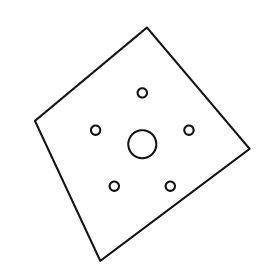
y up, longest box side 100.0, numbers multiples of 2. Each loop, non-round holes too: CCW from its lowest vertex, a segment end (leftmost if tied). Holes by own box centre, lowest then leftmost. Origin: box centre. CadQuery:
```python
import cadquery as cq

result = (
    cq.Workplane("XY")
    .moveTo(-18.0, -50.0)
    .lineTo(46.0, -2.0)
    .lineTo(2.0, 50.0)
    .lineTo(-46.0, 10.0)
    .close()
    .moveTo(-12.0, -18.0)
    .circle(2.0)
    .moveTo(12.0, -18.0)
    .circle(2.0)
    .moveTo(0.0, 0.0)
    .circle(6.0)
    .moveTo(-20.0, 6.0)
    .circle(2.0)
    .moveTo(20.0, 6.0)
    .circle(2.0)
    .moveTo(0.0, 22.0)
    .circle(2.0)
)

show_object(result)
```